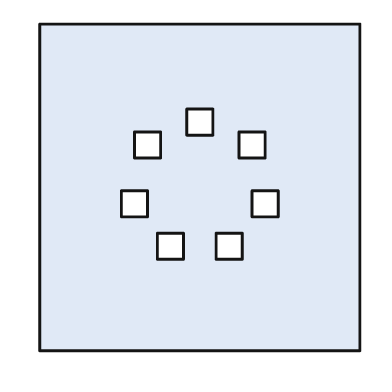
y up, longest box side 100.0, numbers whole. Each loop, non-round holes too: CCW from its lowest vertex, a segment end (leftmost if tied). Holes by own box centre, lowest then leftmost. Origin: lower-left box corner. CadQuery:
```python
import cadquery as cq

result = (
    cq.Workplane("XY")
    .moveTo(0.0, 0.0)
    .lineTo(98.0, 0.0)
    .lineTo(98.0, 100.0)
    .lineTo(0.0, 100.0)
    .close()
    .moveTo(36.0, 28.0)
    .lineTo(44.0, 28.0)
    .lineTo(44.0, 36.0)
    .lineTo(36.0, 36.0)
    .close()
    .moveTo(54.0, 28.0)
    .lineTo(62.0, 28.0)
    .lineTo(62.0, 36.0)
    .lineTo(54.0, 36.0)
    .close()
    .moveTo(25.0, 41.0)
    .lineTo(33.0, 41.0)
    .lineTo(33.0, 49.0)
    .lineTo(25.0, 49.0)
    .close()
    .moveTo(65.0, 41.0)
    .lineTo(73.0, 41.0)
    .lineTo(73.0, 49.0)
    .lineTo(65.0, 49.0)
    .close()
    .moveTo(29.0, 59.0)
    .lineTo(37.0, 59.0)
    .lineTo(37.0, 67.0)
    .lineTo(29.0, 67.0)
    .close()
    .moveTo(61.0, 59.0)
    .lineTo(69.0, 59.0)
    .lineTo(69.0, 67.0)
    .lineTo(61.0, 67.0)
    .close()
    .moveTo(45.0, 66.0)
    .lineTo(53.0, 66.0)
    .lineTo(53.0, 74.0)
    .lineTo(45.0, 74.0)
    .close()
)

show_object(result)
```